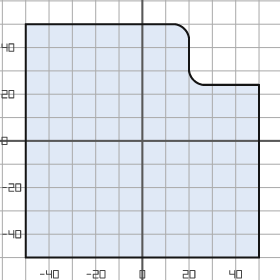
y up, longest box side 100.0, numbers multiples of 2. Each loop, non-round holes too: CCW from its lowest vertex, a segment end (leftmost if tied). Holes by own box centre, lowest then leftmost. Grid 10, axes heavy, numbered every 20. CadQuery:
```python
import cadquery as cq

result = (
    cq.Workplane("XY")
    .moveTo(-50.0, -50.0)
    .lineTo(50.0, -50.0)
    .lineTo(50.0, 24.0)
    .lineTo(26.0, 24.0)
    .threePointArc((22.0, 26.0), (20.0, 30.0))
    .lineTo(20.0, 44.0)
    .threePointArc((18.0, 48.0), (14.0, 50.0))
    .lineTo(-50.0, 50.0)
    .close()
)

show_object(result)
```